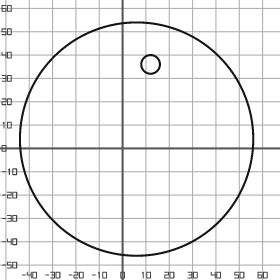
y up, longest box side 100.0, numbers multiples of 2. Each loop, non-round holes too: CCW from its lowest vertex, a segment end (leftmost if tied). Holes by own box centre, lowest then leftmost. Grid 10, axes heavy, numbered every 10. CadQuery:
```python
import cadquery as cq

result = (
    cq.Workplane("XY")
    .moveTo(6.0, 4.0)
    .circle(50.0)
    .moveTo(12.0, 36.0)
    .circle(4.0)
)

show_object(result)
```